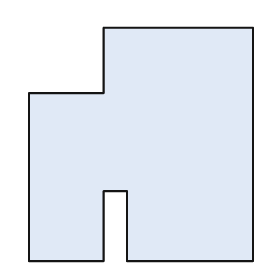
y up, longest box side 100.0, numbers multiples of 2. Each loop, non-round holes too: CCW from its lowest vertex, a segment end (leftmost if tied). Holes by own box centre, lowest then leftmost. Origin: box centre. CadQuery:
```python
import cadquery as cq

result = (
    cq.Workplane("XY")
    .moveTo(-48.0, -50.0)
    .lineTo(-16.0, -50.0)
    .lineTo(-16.0, -20.0)
    .lineTo(-6.0, -20.0)
    .lineTo(-6.0, -50.0)
    .lineTo(48.0, -50.0)
    .lineTo(48.0, 50.0)
    .lineTo(-16.0, 50.0)
    .lineTo(-16.0, 22.0)
    .lineTo(-48.0, 22.0)
    .close()
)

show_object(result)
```